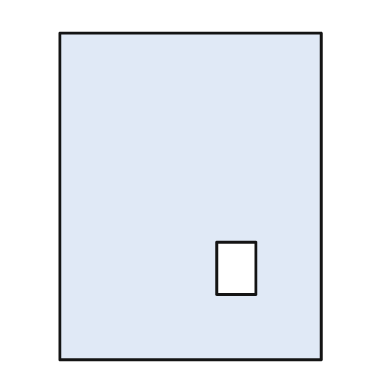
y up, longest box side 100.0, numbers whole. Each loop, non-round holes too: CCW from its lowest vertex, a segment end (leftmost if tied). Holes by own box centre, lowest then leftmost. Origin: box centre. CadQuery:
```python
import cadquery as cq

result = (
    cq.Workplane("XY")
    .moveTo(-40.0, -50.0)
    .lineTo(40.0, -50.0)
    .lineTo(40.0, 50.0)
    .lineTo(-40.0, 50.0)
    .close()
    .moveTo(8.0, -30.0)
    .lineTo(20.0, -30.0)
    .lineTo(20.0, -14.0)
    .lineTo(8.0, -14.0)
    .close()
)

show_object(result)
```